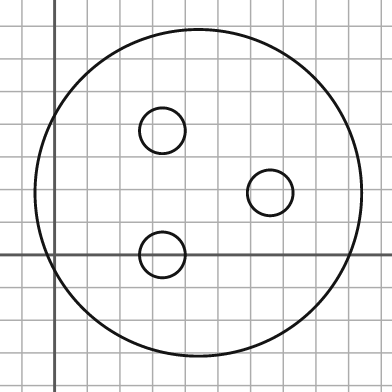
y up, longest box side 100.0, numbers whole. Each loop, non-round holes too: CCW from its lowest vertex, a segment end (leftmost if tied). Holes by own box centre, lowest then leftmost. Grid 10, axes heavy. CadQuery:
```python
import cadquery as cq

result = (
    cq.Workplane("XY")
    .moveTo(44.0, 19.0)
    .circle(50.0)
    .moveTo(33.0, 0.0)
    .circle(7.0)
    .moveTo(66.0, 19.0)
    .circle(7.0)
    .moveTo(33.0, 38.0)
    .circle(7.0)
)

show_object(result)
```